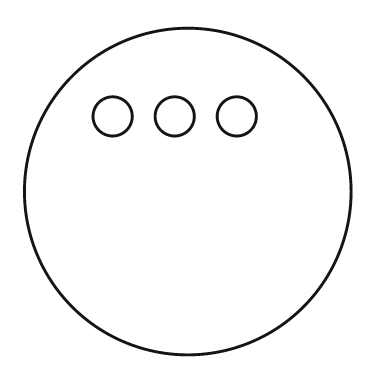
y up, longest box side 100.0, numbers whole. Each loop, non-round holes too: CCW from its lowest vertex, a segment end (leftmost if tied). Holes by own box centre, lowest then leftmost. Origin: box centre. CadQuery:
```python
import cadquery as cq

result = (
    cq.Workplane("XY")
    .moveTo(0.0, 0.0)
    .circle(50.0)
    .moveTo(-23.0, 23.0)
    .circle(6.0)
    .moveTo(-4.0, 23.0)
    .circle(6.0)
    .moveTo(15.0, 23.0)
    .circle(6.0)
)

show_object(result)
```